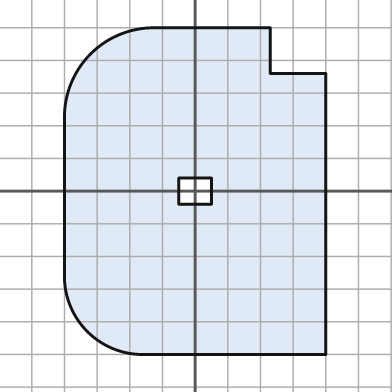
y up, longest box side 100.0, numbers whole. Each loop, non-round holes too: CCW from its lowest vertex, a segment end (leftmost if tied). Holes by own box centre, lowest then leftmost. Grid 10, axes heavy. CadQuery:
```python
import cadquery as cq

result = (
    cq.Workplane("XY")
    .moveTo(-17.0, -50.0)
    .lineTo(40.0, -50.0)
    .lineTo(40.0, 36.0)
    .lineTo(23.0, 36.0)
    .lineTo(23.0, 50.0)
    .lineTo(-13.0, 50.0)
    .threePointArc((-32.0, 42.0), (-40.0, 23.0))
    .lineTo(-40.0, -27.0)
    .threePointArc((-33.0, -43.0), (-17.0, -50.0))
    .close()
    .moveTo(-5.0, -4.0)
    .lineTo(5.0, -4.0)
    .lineTo(5.0, 4.0)
    .lineTo(-5.0, 4.0)
    .close()
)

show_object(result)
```